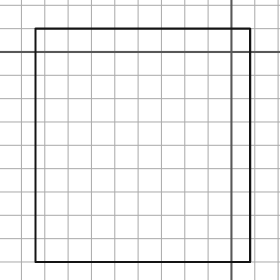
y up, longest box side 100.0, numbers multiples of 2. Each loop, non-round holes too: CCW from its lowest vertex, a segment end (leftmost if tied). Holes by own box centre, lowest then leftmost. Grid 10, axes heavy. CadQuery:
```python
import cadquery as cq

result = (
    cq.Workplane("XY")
    .moveTo(-84.0, -90.0)
    .lineTo(8.0, -90.0)
    .lineTo(8.0, 10.0)
    .lineTo(-84.0, 10.0)
    .close()
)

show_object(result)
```